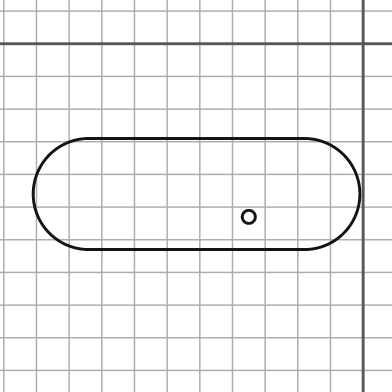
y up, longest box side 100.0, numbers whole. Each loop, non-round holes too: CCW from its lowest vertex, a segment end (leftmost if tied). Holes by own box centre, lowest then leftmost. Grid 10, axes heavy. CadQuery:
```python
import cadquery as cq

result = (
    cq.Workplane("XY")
    .moveTo(-84.0, -63.0)
    .lineTo(-18.0, -63.0)
    .threePointArc((-1.0, -46.0), (-18.0, -29.0))
    .lineTo(-84.0, -29.0)
    .threePointArc((-101.0, -46.0), (-84.0, -63.0))
    .close()
    .moveTo(-35.0, -53.0)
    .circle(2.0)
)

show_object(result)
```